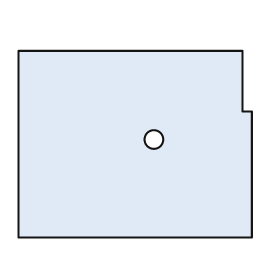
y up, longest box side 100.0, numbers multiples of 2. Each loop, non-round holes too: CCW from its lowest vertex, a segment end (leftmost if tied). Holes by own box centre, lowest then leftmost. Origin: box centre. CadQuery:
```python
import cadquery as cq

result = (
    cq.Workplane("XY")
    .moveTo(-50.0, -40.0)
    .lineTo(50.0, -40.0)
    .lineTo(50.0, 14.0)
    .lineTo(46.0, 14.0)
    .lineTo(46.0, 40.0)
    .lineTo(-50.0, 40.0)
    .close()
    .moveTo(8.0, 2.0)
    .circle(4.0)
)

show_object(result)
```